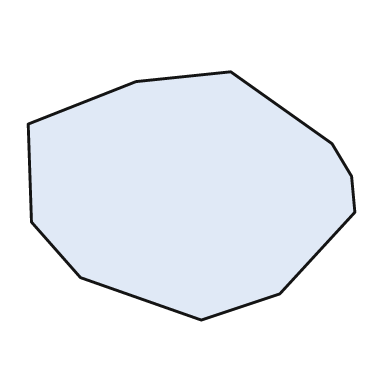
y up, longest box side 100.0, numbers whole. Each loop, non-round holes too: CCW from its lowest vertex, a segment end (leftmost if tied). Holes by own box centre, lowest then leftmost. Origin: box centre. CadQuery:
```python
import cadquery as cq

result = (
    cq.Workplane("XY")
    .moveTo(3.0, -38.0)
    .lineTo(27.0, -30.0)
    .lineTo(50.0, -5.0)
    .lineTo(49.0, 6.0)
    .lineTo(43.0, 16.0)
    .lineTo(12.0, 38.0)
    .lineTo(-17.0, 35.0)
    .lineTo(-50.0, 22.0)
    .lineTo(-49.0, -8.0)
    .lineTo(-34.0, -25.0)
    .close()
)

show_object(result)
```